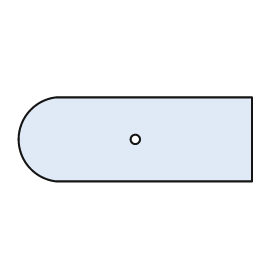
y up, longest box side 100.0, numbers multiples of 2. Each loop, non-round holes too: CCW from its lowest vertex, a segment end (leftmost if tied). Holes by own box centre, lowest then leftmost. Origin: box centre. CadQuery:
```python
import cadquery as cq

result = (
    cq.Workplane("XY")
    .moveTo(-34.0, -18.0)
    .lineTo(50.0, -18.0)
    .lineTo(50.0, 18.0)
    .lineTo(-34.0, 18.0)
    .threePointArc((-50.0, 0.0), (-34.0, -18.0))
    .close()
    .moveTo(0.0, 0.0)
    .circle(2.0)
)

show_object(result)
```